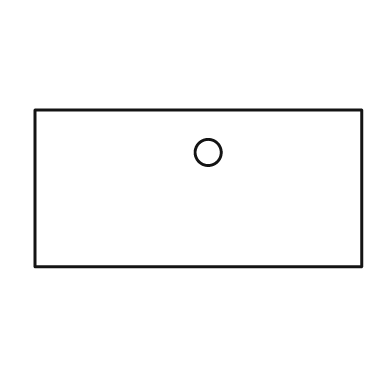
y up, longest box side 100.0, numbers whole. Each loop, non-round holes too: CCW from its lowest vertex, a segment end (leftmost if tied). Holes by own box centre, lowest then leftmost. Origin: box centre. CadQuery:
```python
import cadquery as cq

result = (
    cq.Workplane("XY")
    .moveTo(-50.0, -24.0)
    .lineTo(50.0, -24.0)
    .lineTo(50.0, 24.0)
    .lineTo(-50.0, 24.0)
    .close()
    .moveTo(3.0, 11.0)
    .circle(4.0)
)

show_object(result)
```